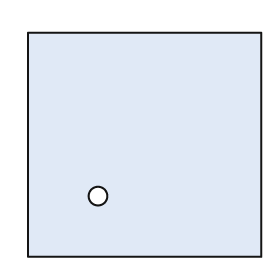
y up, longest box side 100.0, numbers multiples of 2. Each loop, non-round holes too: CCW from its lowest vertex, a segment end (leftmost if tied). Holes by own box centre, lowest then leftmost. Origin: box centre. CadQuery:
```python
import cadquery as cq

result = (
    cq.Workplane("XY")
    .moveTo(-50.0, -48.0)
    .lineTo(50.0, -48.0)
    .lineTo(50.0, 48.0)
    .lineTo(-50.0, 48.0)
    .close()
    .moveTo(-20.0, -22.0)
    .circle(4.0)
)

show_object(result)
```